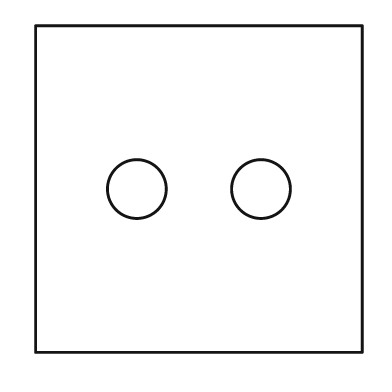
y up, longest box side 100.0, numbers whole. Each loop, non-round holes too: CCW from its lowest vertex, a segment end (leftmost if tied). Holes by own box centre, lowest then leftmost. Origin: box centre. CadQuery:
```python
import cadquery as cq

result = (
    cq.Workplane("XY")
    .moveTo(-50.0, -50.0)
    .lineTo(50.0, -50.0)
    .lineTo(50.0, 50.0)
    .lineTo(-50.0, 50.0)
    .close()
    .moveTo(-19.0, 0.0)
    .circle(9.0)
    .moveTo(19.0, 0.0)
    .circle(9.0)
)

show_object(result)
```